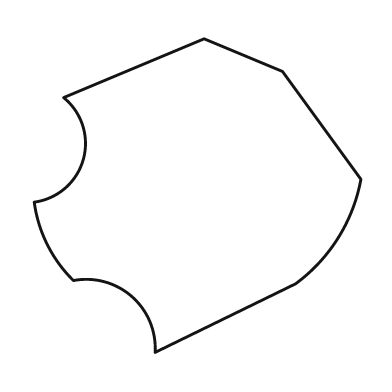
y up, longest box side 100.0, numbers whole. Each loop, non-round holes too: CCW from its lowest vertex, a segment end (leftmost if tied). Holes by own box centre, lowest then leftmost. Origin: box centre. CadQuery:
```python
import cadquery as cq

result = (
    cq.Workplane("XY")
    .moveTo(-13.0, -48.0)
    .lineTo(30.0, -27.0)
    .threePointArc((43.0, -13.0), (50.0, 5.0))
    .lineTo(26.0, 38.0)
    .lineTo(2.0, 48.0)
    .lineTo(-41.0, 30.0)
    .threePointArc((-35.0, 11.0), (-50.0, -2.0))
    .threePointArc((-46.0, -15.0), (-38.0, -26.0))
    .threePointArc((-20.0, -31.0), (-13.0, -48.0))
    .close()
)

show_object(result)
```